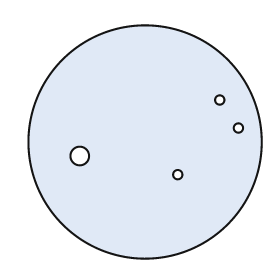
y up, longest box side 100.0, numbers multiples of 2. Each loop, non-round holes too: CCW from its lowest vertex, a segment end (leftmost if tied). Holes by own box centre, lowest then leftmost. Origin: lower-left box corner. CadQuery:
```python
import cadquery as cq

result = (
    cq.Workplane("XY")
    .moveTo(50.0, 50.0)
    .circle(50.0)
    .moveTo(64.0, 36.0)
    .circle(2.0)
    .moveTo(22.0, 44.0)
    .circle(4.0)
    .moveTo(90.0, 56.0)
    .circle(2.0)
    .moveTo(82.0, 68.0)
    .circle(2.0)
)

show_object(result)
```